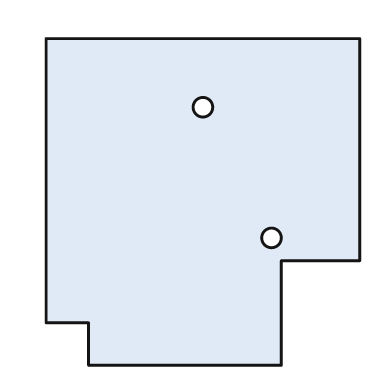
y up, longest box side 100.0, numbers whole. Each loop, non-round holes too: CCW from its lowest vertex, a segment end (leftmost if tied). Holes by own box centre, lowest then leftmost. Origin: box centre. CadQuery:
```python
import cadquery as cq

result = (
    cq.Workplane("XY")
    .moveTo(-35.0, -50.0)
    .lineTo(24.0, -50.0)
    .lineTo(24.0, -18.0)
    .lineTo(48.0, -18.0)
    .lineTo(48.0, 50.0)
    .lineTo(-48.0, 50.0)
    .lineTo(-48.0, -37.0)
    .lineTo(-35.0, -37.0)
    .close()
    .moveTo(21.0, -11.0)
    .circle(3.0)
    .moveTo(0.0, 29.0)
    .circle(3.0)
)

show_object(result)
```